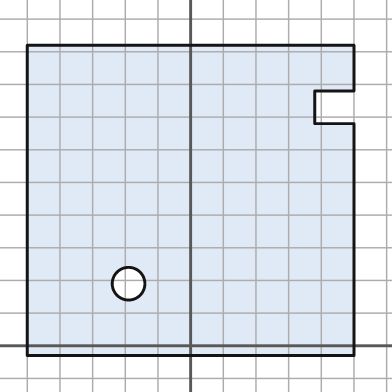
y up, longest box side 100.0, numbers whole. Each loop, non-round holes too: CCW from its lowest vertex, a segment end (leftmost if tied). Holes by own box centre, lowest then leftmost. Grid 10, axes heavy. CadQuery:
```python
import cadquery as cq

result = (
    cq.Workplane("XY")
    .moveTo(-50.0, -3.0)
    .lineTo(50.0, -3.0)
    .lineTo(50.0, 68.0)
    .lineTo(38.0, 68.0)
    .lineTo(38.0, 78.0)
    .lineTo(50.0, 78.0)
    .lineTo(50.0, 92.0)
    .lineTo(-50.0, 92.0)
    .close()
    .moveTo(-19.0, 19.0)
    .circle(5.0)
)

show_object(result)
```